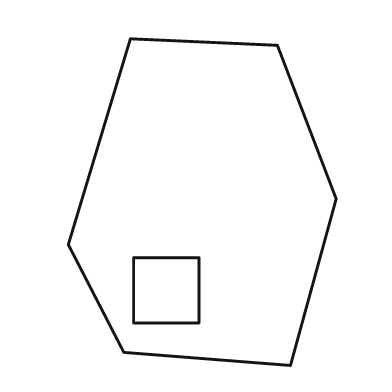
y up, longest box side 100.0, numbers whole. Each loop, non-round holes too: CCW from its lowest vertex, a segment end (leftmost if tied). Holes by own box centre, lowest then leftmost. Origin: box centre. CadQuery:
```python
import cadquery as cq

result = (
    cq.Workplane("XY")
    .moveTo(27.0, -50.0)
    .lineTo(41.0, 1.0)
    .lineTo(23.0, 48.0)
    .lineTo(-22.0, 50.0)
    .lineTo(-41.0, -13.0)
    .lineTo(-24.0, -46.0)
    .close()
    .moveTo(-21.0, -37.0)
    .lineTo(-1.0, -37.0)
    .lineTo(-1.0, -17.0)
    .lineTo(-21.0, -17.0)
    .close()
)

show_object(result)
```